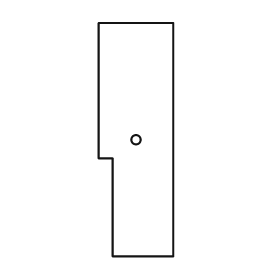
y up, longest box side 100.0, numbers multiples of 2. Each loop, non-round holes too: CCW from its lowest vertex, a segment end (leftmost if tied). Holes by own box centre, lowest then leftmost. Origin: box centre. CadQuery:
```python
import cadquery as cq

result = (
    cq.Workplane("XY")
    .moveTo(-10.0, -50.0)
    .lineTo(16.0, -50.0)
    .lineTo(16.0, 50.0)
    .lineTo(-16.0, 50.0)
    .lineTo(-16.0, -8.0)
    .lineTo(-10.0, -8.0)
    .close()
    .moveTo(0.0, 0.0)
    .circle(2.0)
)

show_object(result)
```